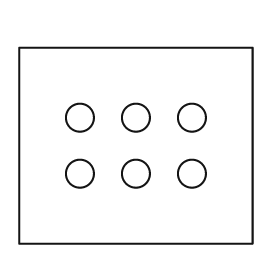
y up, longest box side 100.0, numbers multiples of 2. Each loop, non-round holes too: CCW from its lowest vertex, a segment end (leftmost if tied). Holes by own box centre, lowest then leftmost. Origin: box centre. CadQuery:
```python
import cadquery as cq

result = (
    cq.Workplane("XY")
    .moveTo(-50.0, -42.0)
    .lineTo(50.0, -42.0)
    .lineTo(50.0, 42.0)
    .lineTo(-50.0, 42.0)
    .close()
    .moveTo(-24.0, -12.0)
    .circle(6.0)
    .moveTo(0.0, -12.0)
    .circle(6.0)
    .moveTo(24.0, -12.0)
    .circle(6.0)
    .moveTo(-24.0, 12.0)
    .circle(6.0)
    .moveTo(0.0, 12.0)
    .circle(6.0)
    .moveTo(24.0, 12.0)
    .circle(6.0)
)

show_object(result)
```